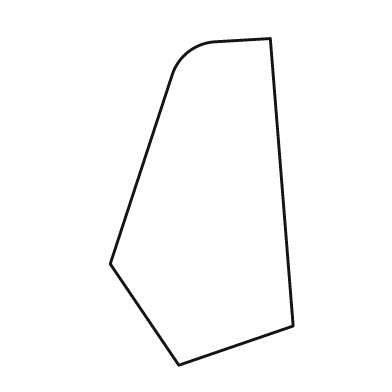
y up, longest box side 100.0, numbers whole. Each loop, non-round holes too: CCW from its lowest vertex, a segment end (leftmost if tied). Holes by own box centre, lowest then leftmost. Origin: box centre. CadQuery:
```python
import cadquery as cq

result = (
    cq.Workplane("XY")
    .moveTo(-7.0, -50.0)
    .lineTo(28.0, -38.0)
    .lineTo(21.0, 50.0)
    .lineTo(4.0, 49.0)
    .threePointArc((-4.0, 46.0), (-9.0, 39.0))
    .lineTo(-28.0, -19.0)
    .close()
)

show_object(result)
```